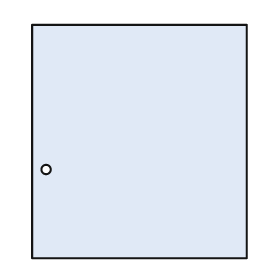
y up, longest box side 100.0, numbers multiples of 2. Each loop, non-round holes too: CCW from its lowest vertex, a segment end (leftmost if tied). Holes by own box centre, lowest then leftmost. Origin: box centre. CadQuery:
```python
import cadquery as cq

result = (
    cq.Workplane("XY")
    .moveTo(-46.0, -50.0)
    .lineTo(46.0, -50.0)
    .lineTo(46.0, 50.0)
    .lineTo(-46.0, 50.0)
    .close()
    .moveTo(-40.0, -12.0)
    .circle(2.0)
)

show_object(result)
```